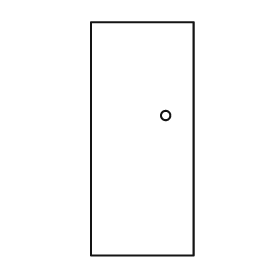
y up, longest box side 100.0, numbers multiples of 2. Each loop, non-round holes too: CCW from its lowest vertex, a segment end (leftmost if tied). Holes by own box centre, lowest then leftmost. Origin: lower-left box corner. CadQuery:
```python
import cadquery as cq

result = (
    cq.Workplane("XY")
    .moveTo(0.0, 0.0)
    .lineTo(44.0, 0.0)
    .lineTo(44.0, 100.0)
    .lineTo(0.0, 100.0)
    .close()
    .moveTo(32.0, 60.0)
    .circle(2.0)
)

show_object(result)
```